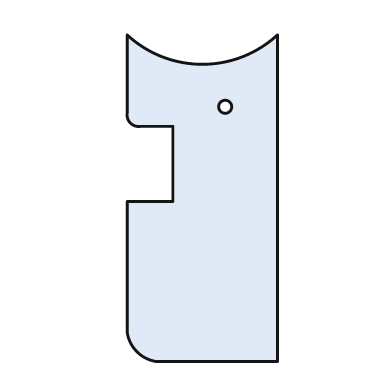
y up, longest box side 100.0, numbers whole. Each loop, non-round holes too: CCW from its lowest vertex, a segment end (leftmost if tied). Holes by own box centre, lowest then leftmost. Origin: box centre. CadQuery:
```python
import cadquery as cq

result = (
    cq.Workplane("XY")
    .moveTo(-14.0, -50.0)
    .lineTo(23.0, -50.0)
    .lineTo(23.0, 50.0)
    .threePointArc((0.0, 41.0), (-23.0, 50.0))
    .lineTo(-23.0, 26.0)
    .threePointArc((-22.0, 23.0), (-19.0, 22.0))
    .lineTo(-9.0, 22.0)
    .lineTo(-9.0, -1.0)
    .lineTo(-23.0, -1.0)
    .lineTo(-23.0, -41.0)
    .threePointArc((-20.0, -47.0), (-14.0, -50.0))
    .close()
    .moveTo(7.0, 28.0)
    .circle(2.0)
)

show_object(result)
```